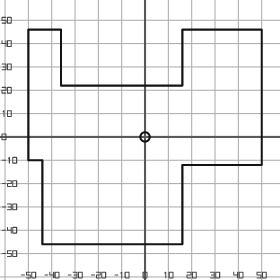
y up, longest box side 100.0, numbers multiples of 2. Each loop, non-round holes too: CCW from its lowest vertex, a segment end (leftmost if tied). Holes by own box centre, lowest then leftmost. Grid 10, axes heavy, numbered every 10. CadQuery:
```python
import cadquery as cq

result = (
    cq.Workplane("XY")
    .moveTo(-44.0, -46.0)
    .lineTo(16.0, -46.0)
    .lineTo(16.0, -12.0)
    .lineTo(50.0, -12.0)
    .lineTo(50.0, 46.0)
    .lineTo(16.0, 46.0)
    .lineTo(16.0, 22.0)
    .lineTo(-36.0, 22.0)
    .lineTo(-36.0, 46.0)
    .lineTo(-50.0, 46.0)
    .lineTo(-50.0, -10.0)
    .lineTo(-44.0, -10.0)
    .close()
    .moveTo(0.0, 0.0)
    .circle(2.0)
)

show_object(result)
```